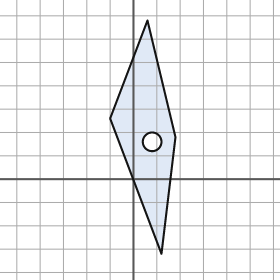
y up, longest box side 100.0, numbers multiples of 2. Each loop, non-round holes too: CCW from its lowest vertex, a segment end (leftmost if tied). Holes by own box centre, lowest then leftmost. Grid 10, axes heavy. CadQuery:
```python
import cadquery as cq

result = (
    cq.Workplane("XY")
    .moveTo(12.0, -32.0)
    .lineTo(18.0, 18.0)
    .lineTo(6.0, 68.0)
    .lineTo(-10.0, 26.0)
    .close()
    .moveTo(8.0, 16.0)
    .circle(4.0)
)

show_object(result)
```